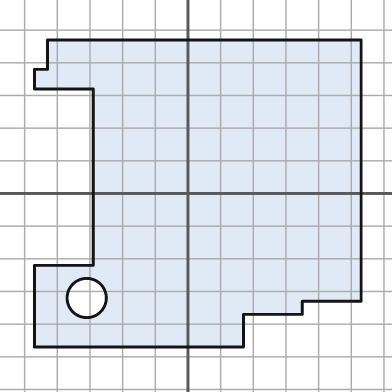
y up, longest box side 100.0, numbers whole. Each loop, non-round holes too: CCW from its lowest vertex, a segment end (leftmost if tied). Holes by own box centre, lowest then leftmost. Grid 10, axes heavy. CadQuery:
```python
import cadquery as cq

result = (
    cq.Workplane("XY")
    .moveTo(-47.0, -47.0)
    .lineTo(17.0, -47.0)
    .lineTo(17.0, -37.0)
    .lineTo(35.0, -37.0)
    .lineTo(35.0, -33.0)
    .lineTo(53.0, -33.0)
    .lineTo(53.0, 47.0)
    .lineTo(-43.0, 47.0)
    .lineTo(-43.0, 38.0)
    .lineTo(-47.0, 38.0)
    .lineTo(-47.0, 32.0)
    .lineTo(-29.0, 32.0)
    .lineTo(-29.0, -22.0)
    .lineTo(-47.0, -22.0)
    .close()
    .moveTo(-31.0, -32.0)
    .circle(6.0)
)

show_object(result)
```